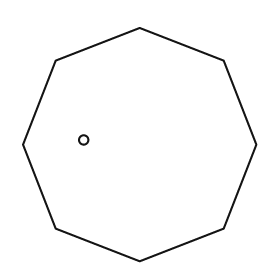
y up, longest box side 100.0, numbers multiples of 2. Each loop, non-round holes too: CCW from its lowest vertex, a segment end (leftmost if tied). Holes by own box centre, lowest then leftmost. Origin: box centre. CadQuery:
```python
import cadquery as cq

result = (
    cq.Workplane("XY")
    .moveTo(0.0, -50.0)
    .lineTo(36.0, -36.0)
    .lineTo(50.0, 0.0)
    .lineTo(36.0, 36.0)
    .lineTo(0.0, 50.0)
    .lineTo(-36.0, 36.0)
    .lineTo(-50.0, 0.0)
    .lineTo(-36.0, -36.0)
    .close()
    .moveTo(-24.0, 2.0)
    .circle(2.0)
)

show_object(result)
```